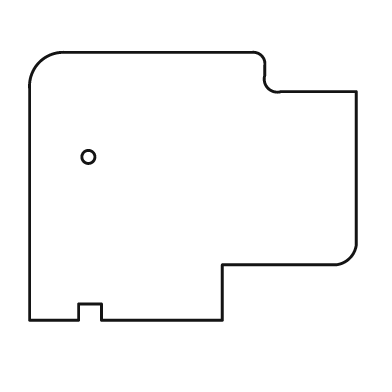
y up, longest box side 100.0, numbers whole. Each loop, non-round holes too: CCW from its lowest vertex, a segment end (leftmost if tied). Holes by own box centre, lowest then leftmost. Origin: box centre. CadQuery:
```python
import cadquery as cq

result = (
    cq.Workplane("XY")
    .moveTo(-50.0, -41.0)
    .lineTo(-35.0, -41.0)
    .lineTo(-35.0, -36.0)
    .lineTo(-28.0, -36.0)
    .lineTo(-28.0, -41.0)
    .lineTo(9.0, -41.0)
    .lineTo(9.0, -24.0)
    .lineTo(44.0, -24.0)
    .threePointArc((48.0, -22.0), (50.0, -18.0))
    .lineTo(50.0, 29.0)
    .lineTo(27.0, 29.0)
    .threePointArc((23.0, 30.0), (22.0, 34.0))
    .lineTo(22.0, 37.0)
    .threePointArc((21.0, 40.0), (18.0, 41.0))
    .lineTo(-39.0, 41.0)
    .threePointArc((-47.0, 38.0), (-50.0, 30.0))
    .close()
    .moveTo(-32.0, 9.0)
    .circle(2.0)
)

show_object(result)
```